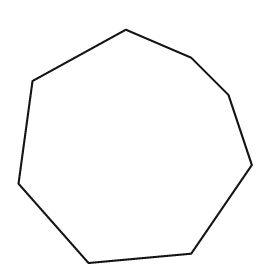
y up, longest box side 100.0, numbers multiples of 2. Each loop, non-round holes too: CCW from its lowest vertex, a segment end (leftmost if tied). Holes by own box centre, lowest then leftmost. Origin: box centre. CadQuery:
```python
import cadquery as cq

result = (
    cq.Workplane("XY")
    .moveTo(-20.0, -50.0)
    .lineTo(24.0, -46.0)
    .lineTo(50.0, -8.0)
    .lineTo(40.0, 22.0)
    .lineTo(24.0, 38.0)
    .lineTo(-4.0, 50.0)
    .lineTo(-44.0, 28.0)
    .lineTo(-50.0, -16.0)
    .close()
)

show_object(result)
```